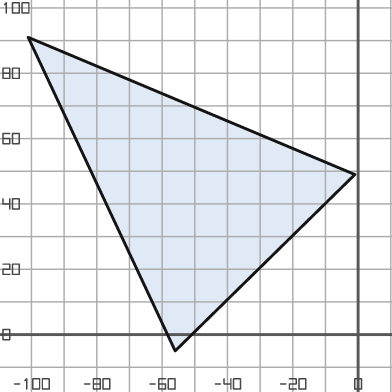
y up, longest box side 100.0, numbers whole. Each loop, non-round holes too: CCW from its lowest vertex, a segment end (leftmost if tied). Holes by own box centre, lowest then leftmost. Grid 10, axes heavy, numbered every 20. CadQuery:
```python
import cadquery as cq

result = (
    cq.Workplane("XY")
    .moveTo(-56.0, -5.0)
    .lineTo(-1.0, 49.0)
    .lineTo(-101.0, 91.0)
    .close()
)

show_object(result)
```